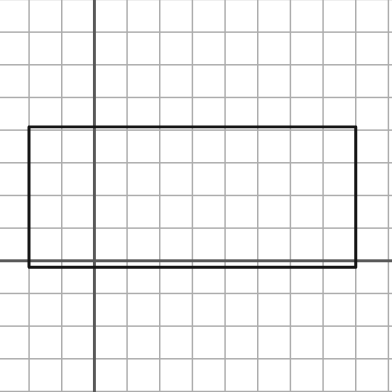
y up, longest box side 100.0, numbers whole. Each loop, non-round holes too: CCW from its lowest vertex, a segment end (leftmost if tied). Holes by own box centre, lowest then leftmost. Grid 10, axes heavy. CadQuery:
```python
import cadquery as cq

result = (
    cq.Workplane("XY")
    .moveTo(-20.0, -2.0)
    .lineTo(80.0, -2.0)
    .lineTo(80.0, 41.0)
    .lineTo(-20.0, 41.0)
    .close()
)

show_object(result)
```